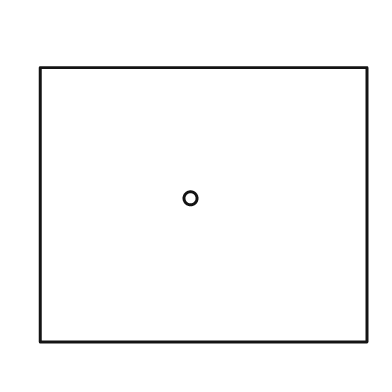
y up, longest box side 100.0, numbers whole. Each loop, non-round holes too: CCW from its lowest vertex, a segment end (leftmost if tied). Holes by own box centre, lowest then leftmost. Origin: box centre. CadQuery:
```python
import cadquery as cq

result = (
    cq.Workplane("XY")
    .moveTo(-50.0, -42.0)
    .lineTo(50.0, -42.0)
    .lineTo(50.0, 42.0)
    .lineTo(-50.0, 42.0)
    .close()
    .moveTo(-4.0, 2.0)
    .circle(2.0)
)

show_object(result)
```